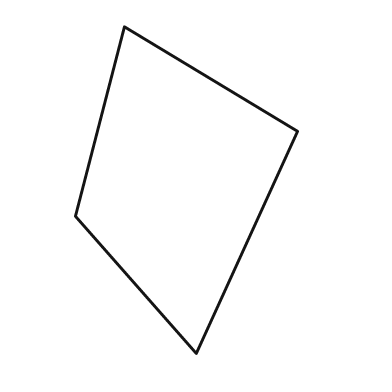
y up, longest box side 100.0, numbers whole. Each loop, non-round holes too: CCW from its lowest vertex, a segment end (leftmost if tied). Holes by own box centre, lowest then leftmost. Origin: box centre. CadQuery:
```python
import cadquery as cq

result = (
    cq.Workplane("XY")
    .moveTo(3.0, -50.0)
    .lineTo(34.0, 18.0)
    .lineTo(-19.0, 50.0)
    .lineTo(-34.0, -8.0)
    .close()
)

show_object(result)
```